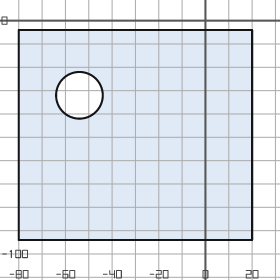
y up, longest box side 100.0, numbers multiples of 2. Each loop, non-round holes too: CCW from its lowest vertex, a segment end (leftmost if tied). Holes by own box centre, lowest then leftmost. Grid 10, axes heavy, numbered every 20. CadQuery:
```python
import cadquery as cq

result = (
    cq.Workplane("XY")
    .moveTo(-80.0, -94.0)
    .lineTo(20.0, -94.0)
    .lineTo(20.0, -4.0)
    .lineTo(-80.0, -4.0)
    .close()
    .moveTo(-54.0, -32.0)
    .circle(10.0)
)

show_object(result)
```